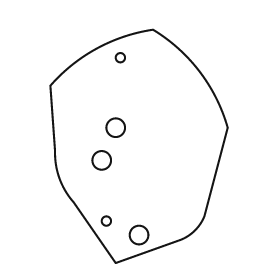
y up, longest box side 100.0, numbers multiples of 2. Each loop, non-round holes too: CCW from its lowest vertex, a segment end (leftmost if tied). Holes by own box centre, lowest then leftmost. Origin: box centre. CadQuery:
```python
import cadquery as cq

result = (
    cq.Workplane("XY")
    .moveTo(-10.0, -50.0)
    .lineTo(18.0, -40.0)
    .threePointArc((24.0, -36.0), (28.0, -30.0))
    .lineTo(38.0, 8.0)
    .threePointArc((26.0, 32.0), (6.0, 50.0))
    .threePointArc((-18.0, 42.0), (-38.0, 26.0))
    .lineTo(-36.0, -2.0)
    .threePointArc((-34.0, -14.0), (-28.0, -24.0))
    .close()
    .moveTo(0.0, -38.0)
    .circle(4.0)
    .moveTo(-14.0, -32.0)
    .circle(2.0)
    .moveTo(-16.0, -6.0)
    .circle(4.0)
    .moveTo(-10.0, 8.0)
    .circle(4.0)
    .moveTo(-8.0, 38.0)
    .circle(2.0)
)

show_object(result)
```